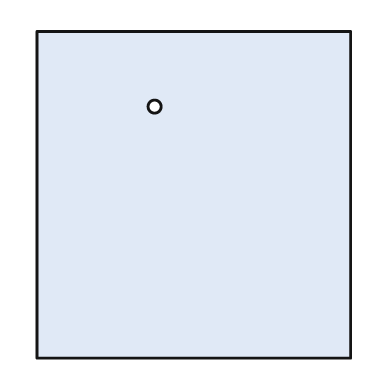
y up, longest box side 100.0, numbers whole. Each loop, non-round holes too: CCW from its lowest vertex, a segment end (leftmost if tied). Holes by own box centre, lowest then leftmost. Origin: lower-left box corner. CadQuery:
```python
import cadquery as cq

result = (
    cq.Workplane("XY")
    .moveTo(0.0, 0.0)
    .lineTo(96.0, 0.0)
    .lineTo(96.0, 100.0)
    .lineTo(0.0, 100.0)
    .close()
    .moveTo(36.0, 77.0)
    .circle(2.0)
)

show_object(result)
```